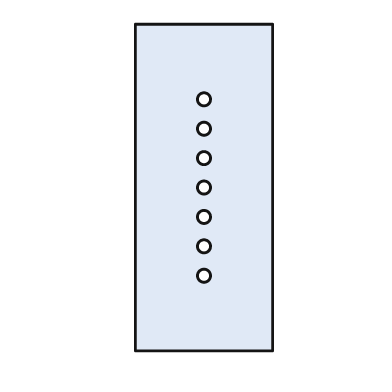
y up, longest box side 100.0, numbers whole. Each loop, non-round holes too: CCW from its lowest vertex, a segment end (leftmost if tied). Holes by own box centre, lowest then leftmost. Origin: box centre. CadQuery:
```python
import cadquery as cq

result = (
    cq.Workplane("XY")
    .moveTo(-21.0, -50.0)
    .lineTo(21.0, -50.0)
    .lineTo(21.0, 50.0)
    .lineTo(-21.0, 50.0)
    .close()
    .moveTo(0.0, -27.0)
    .circle(2.0)
    .moveTo(0.0, -18.0)
    .circle(2.0)
    .moveTo(0.0, -9.0)
    .circle(2.0)
    .moveTo(0.0, 0.0)
    .circle(2.0)
    .moveTo(0.0, 9.0)
    .circle(2.0)
    .moveTo(0.0, 18.0)
    .circle(2.0)
    .moveTo(0.0, 27.0)
    .circle(2.0)
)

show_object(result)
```